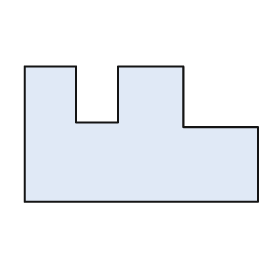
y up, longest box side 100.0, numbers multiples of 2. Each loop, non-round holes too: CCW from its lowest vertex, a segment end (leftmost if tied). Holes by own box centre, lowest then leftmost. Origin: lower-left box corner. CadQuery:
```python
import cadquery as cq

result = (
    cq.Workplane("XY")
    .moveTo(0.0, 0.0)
    .lineTo(100.0, 0.0)
    .lineTo(100.0, 32.0)
    .lineTo(68.0, 32.0)
    .lineTo(68.0, 58.0)
    .lineTo(40.0, 58.0)
    .lineTo(40.0, 34.0)
    .lineTo(22.0, 34.0)
    .lineTo(22.0, 58.0)
    .lineTo(0.0, 58.0)
    .close()
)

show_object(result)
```